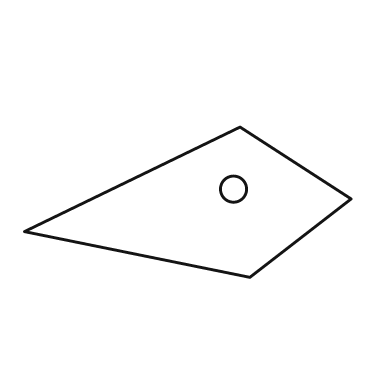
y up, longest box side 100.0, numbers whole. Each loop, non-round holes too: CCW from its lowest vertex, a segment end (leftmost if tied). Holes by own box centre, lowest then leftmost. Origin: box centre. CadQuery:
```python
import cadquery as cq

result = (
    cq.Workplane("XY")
    .moveTo(19.0, -23.0)
    .lineTo(50.0, 1.0)
    .lineTo(16.0, 23.0)
    .lineTo(-50.0, -9.0)
    .close()
    .moveTo(14.0, 4.0)
    .circle(4.0)
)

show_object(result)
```